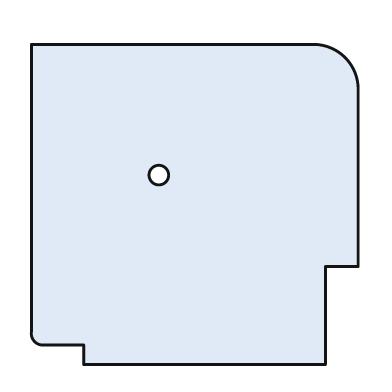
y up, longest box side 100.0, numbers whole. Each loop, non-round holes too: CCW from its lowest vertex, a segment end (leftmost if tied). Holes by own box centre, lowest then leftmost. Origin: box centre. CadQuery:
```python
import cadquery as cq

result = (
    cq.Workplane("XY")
    .moveTo(-34.0, -49.0)
    .lineTo(40.0, -49.0)
    .lineTo(40.0, -19.0)
    .lineTo(50.0, -19.0)
    .lineTo(50.0, 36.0)
    .threePointArc((46.0, 45.0), (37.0, 49.0))
    .lineTo(-50.0, 49.0)
    .lineTo(-50.0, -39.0)
    .threePointArc((-49.0, -42.0), (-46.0, -43.0))
    .lineTo(-34.0, -43.0)
    .close()
    .moveTo(-11.0, 9.0)
    .circle(3.0)
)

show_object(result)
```